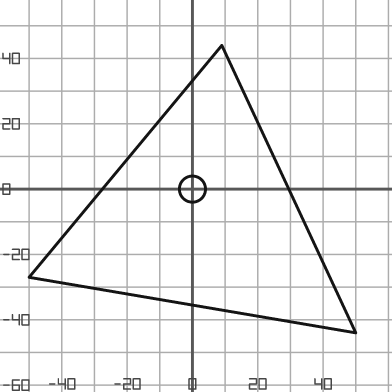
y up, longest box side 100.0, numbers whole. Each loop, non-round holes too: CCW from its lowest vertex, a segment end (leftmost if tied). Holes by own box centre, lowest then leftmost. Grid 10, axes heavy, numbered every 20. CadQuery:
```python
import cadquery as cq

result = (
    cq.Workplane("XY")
    .moveTo(50.0, -44.0)
    .lineTo(9.0, 44.0)
    .lineTo(-50.0, -27.0)
    .close()
    .moveTo(0.0, 0.0)
    .circle(4.0)
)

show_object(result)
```